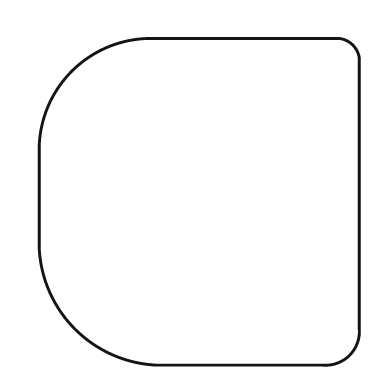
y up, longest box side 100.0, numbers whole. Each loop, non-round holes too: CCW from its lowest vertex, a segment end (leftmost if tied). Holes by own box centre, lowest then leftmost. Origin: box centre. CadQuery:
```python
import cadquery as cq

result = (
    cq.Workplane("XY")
    .moveTo(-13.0, -50.0)
    .lineTo(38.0, -50.0)
    .threePointArc((46.0, -47.0), (49.0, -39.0))
    .lineTo(49.0, 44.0)
    .threePointArc((47.0, 48.0), (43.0, 50.0))
    .lineTo(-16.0, 50.0)
    .threePointArc((-39.0, 40.0), (-49.0, 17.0))
    .lineTo(-49.0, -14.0)
    .threePointArc((-38.0, -39.0), (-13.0, -50.0))
    .close()
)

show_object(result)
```